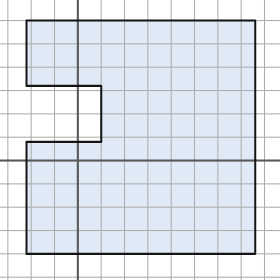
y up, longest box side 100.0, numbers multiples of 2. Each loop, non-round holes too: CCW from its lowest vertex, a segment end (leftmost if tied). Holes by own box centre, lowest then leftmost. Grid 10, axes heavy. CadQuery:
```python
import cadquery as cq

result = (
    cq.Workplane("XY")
    .moveTo(-22.0, -40.0)
    .lineTo(76.0, -40.0)
    .lineTo(76.0, 60.0)
    .lineTo(-22.0, 60.0)
    .lineTo(-22.0, 32.0)
    .lineTo(10.0, 32.0)
    .lineTo(10.0, 8.0)
    .lineTo(-22.0, 8.0)
    .close()
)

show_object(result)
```